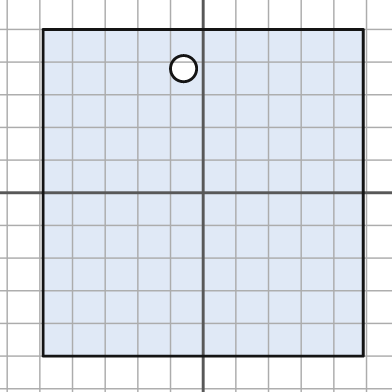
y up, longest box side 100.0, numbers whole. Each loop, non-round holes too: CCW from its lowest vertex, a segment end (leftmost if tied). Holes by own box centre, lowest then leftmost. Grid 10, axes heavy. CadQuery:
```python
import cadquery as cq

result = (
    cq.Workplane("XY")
    .moveTo(-49.0, -50.0)
    .lineTo(49.0, -50.0)
    .lineTo(49.0, 50.0)
    .lineTo(-49.0, 50.0)
    .close()
    .moveTo(-6.0, 38.0)
    .circle(4.0)
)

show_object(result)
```